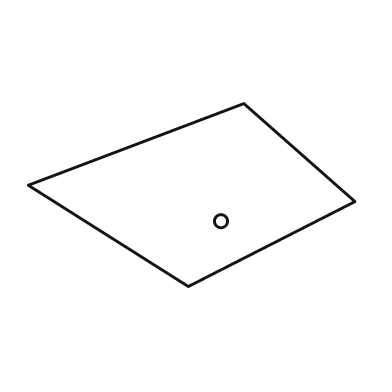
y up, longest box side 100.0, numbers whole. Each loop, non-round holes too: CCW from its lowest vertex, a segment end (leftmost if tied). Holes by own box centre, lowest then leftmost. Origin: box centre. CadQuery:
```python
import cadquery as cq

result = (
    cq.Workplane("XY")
    .moveTo(-1.0, -28.0)
    .lineTo(50.0, -2.0)
    .lineTo(16.0, 28.0)
    .lineTo(-50.0, 3.0)
    .close()
    .moveTo(9.0, -8.0)
    .circle(2.0)
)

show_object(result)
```